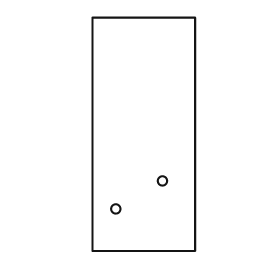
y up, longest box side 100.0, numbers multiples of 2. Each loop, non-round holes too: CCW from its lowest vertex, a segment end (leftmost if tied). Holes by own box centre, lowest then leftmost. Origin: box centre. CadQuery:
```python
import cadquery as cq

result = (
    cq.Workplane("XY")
    .moveTo(-22.0, -50.0)
    .lineTo(22.0, -50.0)
    .lineTo(22.0, 50.0)
    .lineTo(-22.0, 50.0)
    .close()
    .moveTo(-12.0, -32.0)
    .circle(2.0)
    .moveTo(8.0, -20.0)
    .circle(2.0)
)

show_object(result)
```